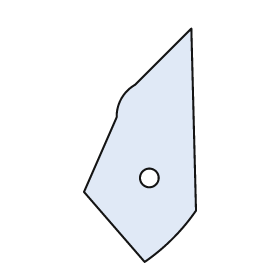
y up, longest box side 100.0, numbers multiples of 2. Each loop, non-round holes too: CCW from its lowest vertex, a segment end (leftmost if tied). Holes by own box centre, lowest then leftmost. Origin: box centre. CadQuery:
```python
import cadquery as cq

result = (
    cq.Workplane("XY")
    .moveTo(2.0, -50.0)
    .threePointArc((14.0, -40.0), (24.0, -28.0))
    .lineTo(22.0, 50.0)
    .lineTo(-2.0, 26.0)
    .threePointArc((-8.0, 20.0), (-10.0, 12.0))
    .lineTo(-24.0, -20.0)
    .close()
    .moveTo(4.0, -14.0)
    .circle(4.0)
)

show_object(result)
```